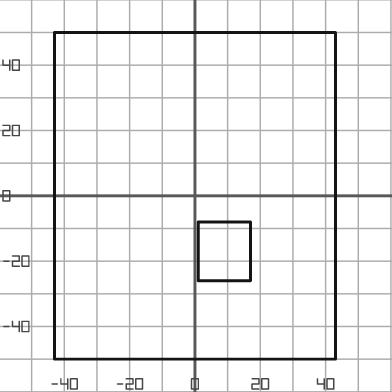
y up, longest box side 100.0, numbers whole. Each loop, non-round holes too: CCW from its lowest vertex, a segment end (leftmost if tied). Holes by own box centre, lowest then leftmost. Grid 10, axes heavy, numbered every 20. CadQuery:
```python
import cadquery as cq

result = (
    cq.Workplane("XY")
    .moveTo(-43.0, -50.0)
    .lineTo(43.0, -50.0)
    .lineTo(43.0, 50.0)
    .lineTo(-43.0, 50.0)
    .close()
    .moveTo(1.0, -26.0)
    .lineTo(17.0, -26.0)
    .lineTo(17.0, -8.0)
    .lineTo(1.0, -8.0)
    .close()
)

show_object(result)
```